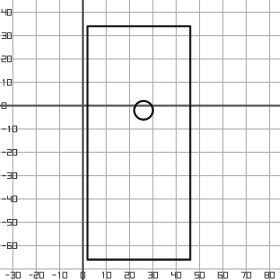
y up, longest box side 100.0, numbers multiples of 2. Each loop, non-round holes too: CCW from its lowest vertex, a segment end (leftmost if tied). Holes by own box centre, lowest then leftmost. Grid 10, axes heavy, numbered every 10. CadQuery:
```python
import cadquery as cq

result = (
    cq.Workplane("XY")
    .moveTo(2.0, -66.0)
    .lineTo(46.0, -66.0)
    .lineTo(46.0, 34.0)
    .lineTo(2.0, 34.0)
    .close()
    .moveTo(26.0, -2.0)
    .circle(4.0)
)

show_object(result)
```